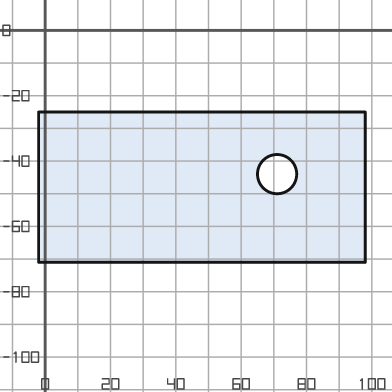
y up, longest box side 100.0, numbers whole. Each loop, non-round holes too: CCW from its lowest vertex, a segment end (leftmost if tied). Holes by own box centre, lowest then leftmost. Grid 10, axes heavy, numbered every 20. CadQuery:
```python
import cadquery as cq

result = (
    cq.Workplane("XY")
    .moveTo(-2.0, -71.0)
    .lineTo(98.0, -71.0)
    .lineTo(98.0, -25.0)
    .lineTo(-2.0, -25.0)
    .close()
    .moveTo(71.0, -44.0)
    .circle(6.0)
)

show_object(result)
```